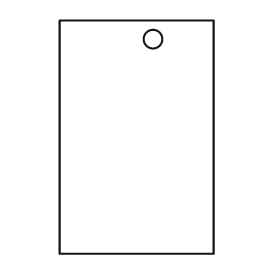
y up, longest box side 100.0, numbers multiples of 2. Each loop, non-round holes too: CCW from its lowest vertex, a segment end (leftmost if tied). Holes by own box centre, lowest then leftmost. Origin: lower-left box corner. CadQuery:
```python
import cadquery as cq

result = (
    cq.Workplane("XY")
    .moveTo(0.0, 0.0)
    .lineTo(66.0, 0.0)
    .lineTo(66.0, 100.0)
    .lineTo(0.0, 100.0)
    .close()
    .moveTo(40.0, 92.0)
    .circle(4.0)
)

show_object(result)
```